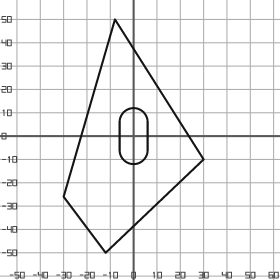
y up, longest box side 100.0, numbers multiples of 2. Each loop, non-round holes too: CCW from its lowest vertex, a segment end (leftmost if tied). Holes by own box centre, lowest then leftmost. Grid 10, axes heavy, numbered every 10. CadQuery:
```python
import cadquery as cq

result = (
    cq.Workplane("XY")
    .moveTo(-12.0, -50.0)
    .lineTo(30.0, -10.0)
    .lineTo(-8.0, 50.0)
    .lineTo(-30.0, -26.0)
    .close()
    .moveTo(-6.0, -6.0)
    .threePointArc((0.0, -12.0), (6.0, -6.0))
    .lineTo(6.0, 6.0)
    .threePointArc((0.0, 12.0), (-6.0, 6.0))
    .close()
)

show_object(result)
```